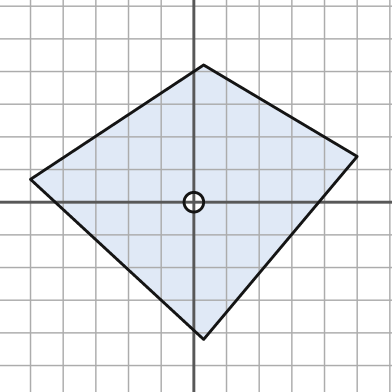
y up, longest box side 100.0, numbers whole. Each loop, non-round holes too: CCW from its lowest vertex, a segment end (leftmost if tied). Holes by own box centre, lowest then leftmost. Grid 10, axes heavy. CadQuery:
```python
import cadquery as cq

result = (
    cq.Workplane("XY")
    .moveTo(3.0, -42.0)
    .lineTo(50.0, 14.0)
    .lineTo(3.0, 42.0)
    .lineTo(-50.0, 7.0)
    .close()
    .moveTo(0.0, 0.0)
    .circle(3.0)
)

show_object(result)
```